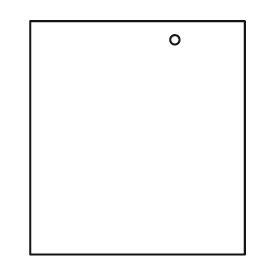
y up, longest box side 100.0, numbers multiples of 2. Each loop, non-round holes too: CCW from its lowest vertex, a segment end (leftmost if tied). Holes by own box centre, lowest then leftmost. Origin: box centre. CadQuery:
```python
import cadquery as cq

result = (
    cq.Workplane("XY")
    .moveTo(-46.0, -50.0)
    .lineTo(46.0, -50.0)
    .lineTo(46.0, 50.0)
    .lineTo(-46.0, 50.0)
    .close()
    .moveTo(16.0, 42.0)
    .circle(2.0)
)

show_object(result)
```